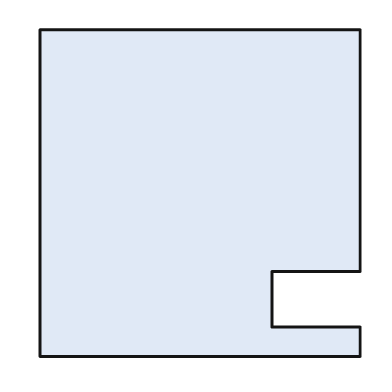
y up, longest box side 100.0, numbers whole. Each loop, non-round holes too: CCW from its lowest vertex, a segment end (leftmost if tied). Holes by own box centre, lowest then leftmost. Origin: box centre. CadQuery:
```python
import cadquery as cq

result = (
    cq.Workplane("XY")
    .moveTo(-49.0, -50.0)
    .lineTo(49.0, -50.0)
    .lineTo(49.0, -41.0)
    .lineTo(22.0, -41.0)
    .lineTo(22.0, -24.0)
    .lineTo(49.0, -24.0)
    .lineTo(49.0, 50.0)
    .lineTo(-49.0, 50.0)
    .close()
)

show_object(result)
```